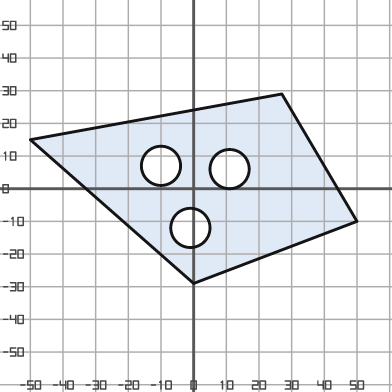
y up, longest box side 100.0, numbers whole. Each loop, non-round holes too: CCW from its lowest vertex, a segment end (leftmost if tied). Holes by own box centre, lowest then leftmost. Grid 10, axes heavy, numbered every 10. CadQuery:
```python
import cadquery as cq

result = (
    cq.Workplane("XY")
    .moveTo(0.0, -29.0)
    .lineTo(50.0, -10.0)
    .lineTo(27.0, 29.0)
    .lineTo(-50.0, 15.0)
    .close()
    .moveTo(-1.0, -12.0)
    .circle(6.0)
    .moveTo(11.0, 6.0)
    .circle(6.0)
    .moveTo(-10.0, 7.0)
    .circle(6.0)
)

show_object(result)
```